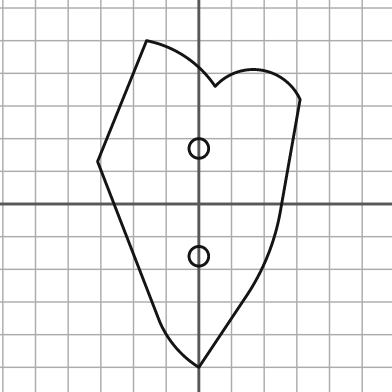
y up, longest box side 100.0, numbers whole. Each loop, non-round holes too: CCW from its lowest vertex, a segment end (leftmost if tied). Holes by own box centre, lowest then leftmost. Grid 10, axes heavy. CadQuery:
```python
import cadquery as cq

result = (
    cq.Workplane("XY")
    .moveTo(0.0, -50.0)
    .lineTo(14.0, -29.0)
    .threePointArc((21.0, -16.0), (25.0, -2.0))
    .lineTo(31.0, 32.0)
    .threePointArc((19.0, 41.0), (5.0, 36.0))
    .threePointArc((-4.0, 45.0), (-16.0, 50.0))
    .lineTo(-31.0, 13.0)
    .lineTo(-12.0, -36.0)
    .threePointArc((-7.0, -44.0), (0.0, -50.0))
    .close()
    .moveTo(0.0, -16.0)
    .circle(3.0)
    .moveTo(0.0, 17.0)
    .circle(3.0)
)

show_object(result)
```